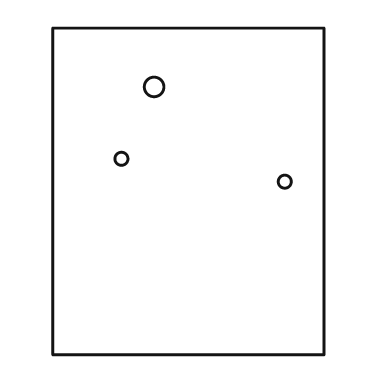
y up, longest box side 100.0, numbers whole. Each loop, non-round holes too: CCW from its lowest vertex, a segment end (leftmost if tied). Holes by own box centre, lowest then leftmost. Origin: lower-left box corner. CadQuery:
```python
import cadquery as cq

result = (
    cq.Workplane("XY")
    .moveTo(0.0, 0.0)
    .lineTo(83.0, 0.0)
    .lineTo(83.0, 100.0)
    .lineTo(0.0, 100.0)
    .close()
    .moveTo(71.0, 53.0)
    .circle(2.0)
    .moveTo(21.0, 60.0)
    .circle(2.0)
    .moveTo(31.0, 82.0)
    .circle(3.0)
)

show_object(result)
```